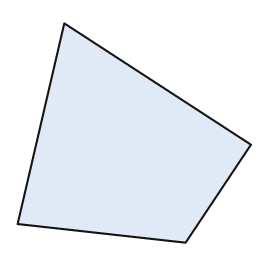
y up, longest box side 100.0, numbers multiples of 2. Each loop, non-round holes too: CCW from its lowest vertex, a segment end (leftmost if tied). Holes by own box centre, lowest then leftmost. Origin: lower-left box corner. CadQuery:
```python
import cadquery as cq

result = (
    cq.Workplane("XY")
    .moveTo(72.0, 0.0)
    .lineTo(100.0, 42.0)
    .lineTo(20.0, 94.0)
    .lineTo(0.0, 8.0)
    .close()
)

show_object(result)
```